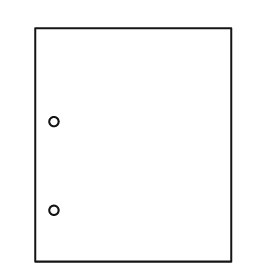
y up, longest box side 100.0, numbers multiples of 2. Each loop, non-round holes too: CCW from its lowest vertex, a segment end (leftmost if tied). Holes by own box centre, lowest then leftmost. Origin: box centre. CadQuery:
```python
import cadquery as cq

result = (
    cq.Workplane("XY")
    .moveTo(-42.0, -50.0)
    .lineTo(42.0, -50.0)
    .lineTo(42.0, 50.0)
    .lineTo(-42.0, 50.0)
    .close()
    .moveTo(-34.0, -28.0)
    .circle(2.0)
    .moveTo(-34.0, 10.0)
    .circle(2.0)
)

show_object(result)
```